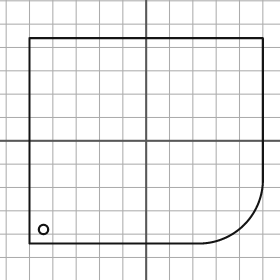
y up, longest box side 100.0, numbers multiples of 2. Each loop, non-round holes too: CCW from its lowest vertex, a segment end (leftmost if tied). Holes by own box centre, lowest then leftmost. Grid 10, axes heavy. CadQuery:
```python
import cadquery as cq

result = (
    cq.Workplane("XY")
    .moveTo(-50.0, -44.0)
    .lineTo(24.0, -44.0)
    .threePointArc((42.0, -36.0), (50.0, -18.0))
    .lineTo(50.0, 44.0)
    .lineTo(-50.0, 44.0)
    .close()
    .moveTo(-44.0, -38.0)
    .circle(2.0)
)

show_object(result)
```